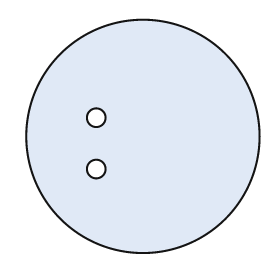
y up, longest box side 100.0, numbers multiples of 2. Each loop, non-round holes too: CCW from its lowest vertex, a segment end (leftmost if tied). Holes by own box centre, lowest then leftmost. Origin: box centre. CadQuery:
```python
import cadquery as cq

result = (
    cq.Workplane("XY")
    .moveTo(0.0, 0.0)
    .circle(50.0)
    .moveTo(-20.0, -14.0)
    .circle(4.0)
    .moveTo(-20.0, 8.0)
    .circle(4.0)
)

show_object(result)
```